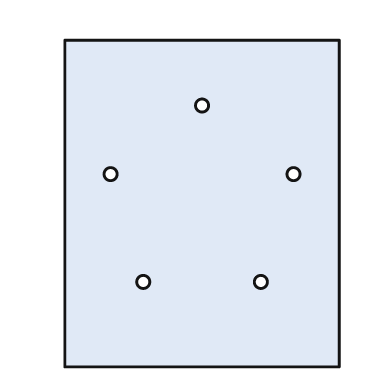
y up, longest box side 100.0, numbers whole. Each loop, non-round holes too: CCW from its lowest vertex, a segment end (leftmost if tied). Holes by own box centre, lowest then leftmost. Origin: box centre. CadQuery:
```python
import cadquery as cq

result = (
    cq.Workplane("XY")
    .moveTo(-42.0, -50.0)
    .lineTo(42.0, -50.0)
    .lineTo(42.0, 50.0)
    .lineTo(-42.0, 50.0)
    .close()
    .moveTo(-18.0, -24.0)
    .circle(2.0)
    .moveTo(18.0, -24.0)
    .circle(2.0)
    .moveTo(-28.0, 9.0)
    .circle(2.0)
    .moveTo(28.0, 9.0)
    .circle(2.0)
    .moveTo(0.0, 30.0)
    .circle(2.0)
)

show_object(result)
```